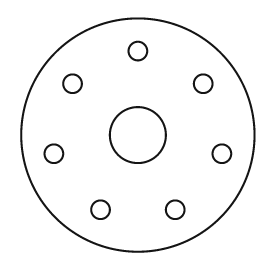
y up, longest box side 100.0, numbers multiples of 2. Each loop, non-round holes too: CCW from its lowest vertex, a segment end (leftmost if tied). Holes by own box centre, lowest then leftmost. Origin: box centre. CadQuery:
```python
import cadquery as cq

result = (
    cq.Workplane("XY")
    .moveTo(0.0, 0.0)
    .circle(50.0)
    .moveTo(-16.0, -32.0)
    .circle(4.0)
    .moveTo(16.0, -32.0)
    .circle(4.0)
    .moveTo(-36.0, -8.0)
    .circle(4.0)
    .moveTo(36.0, -8.0)
    .circle(4.0)
    .moveTo(0.0, 0.0)
    .circle(12.0)
    .moveTo(-28.0, 22.0)
    .circle(4.0)
    .moveTo(28.0, 22.0)
    .circle(4.0)
    .moveTo(0.0, 36.0)
    .circle(4.0)
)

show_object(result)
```